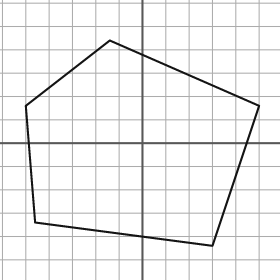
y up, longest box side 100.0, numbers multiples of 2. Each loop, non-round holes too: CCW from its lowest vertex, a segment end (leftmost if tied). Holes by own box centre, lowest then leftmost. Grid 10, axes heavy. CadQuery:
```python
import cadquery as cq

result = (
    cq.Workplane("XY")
    .moveTo(30.0, -44.0)
    .lineTo(50.0, 16.0)
    .lineTo(-14.0, 44.0)
    .lineTo(-50.0, 16.0)
    .lineTo(-46.0, -34.0)
    .close()
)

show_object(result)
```